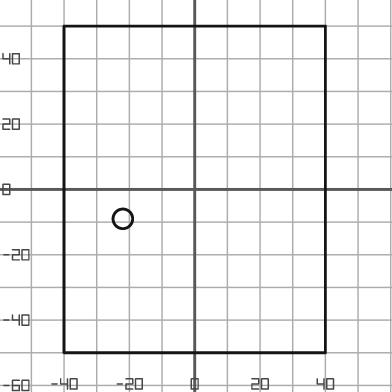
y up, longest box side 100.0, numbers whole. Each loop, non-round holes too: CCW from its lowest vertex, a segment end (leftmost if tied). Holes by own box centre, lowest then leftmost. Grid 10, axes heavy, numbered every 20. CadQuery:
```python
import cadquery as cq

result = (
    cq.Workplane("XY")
    .moveTo(-40.0, -50.0)
    .lineTo(40.0, -50.0)
    .lineTo(40.0, 50.0)
    .lineTo(-40.0, 50.0)
    .close()
    .moveTo(-22.0, -9.0)
    .circle(3.0)
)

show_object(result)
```